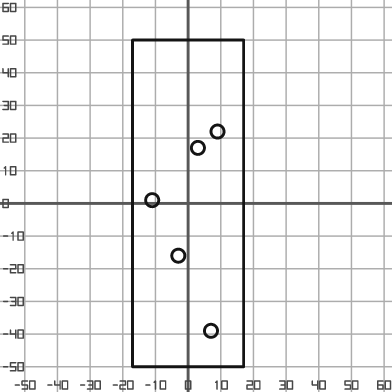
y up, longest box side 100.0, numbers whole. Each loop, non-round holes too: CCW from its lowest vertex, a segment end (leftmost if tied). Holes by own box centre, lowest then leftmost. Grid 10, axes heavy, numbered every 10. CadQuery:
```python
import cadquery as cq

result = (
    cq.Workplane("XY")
    .moveTo(-17.0, -50.0)
    .lineTo(17.0, -50.0)
    .lineTo(17.0, 50.0)
    .lineTo(-17.0, 50.0)
    .close()
    .moveTo(7.0, -39.0)
    .circle(2.0)
    .moveTo(-3.0, -16.0)
    .circle(2.0)
    .moveTo(-11.0, 1.0)
    .circle(2.0)
    .moveTo(3.0, 17.0)
    .circle(2.0)
    .moveTo(9.0, 22.0)
    .circle(2.0)
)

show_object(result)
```